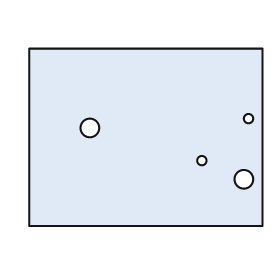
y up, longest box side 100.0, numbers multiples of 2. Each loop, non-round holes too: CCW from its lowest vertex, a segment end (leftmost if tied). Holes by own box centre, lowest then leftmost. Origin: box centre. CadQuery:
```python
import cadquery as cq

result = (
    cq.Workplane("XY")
    .moveTo(-50.0, -38.0)
    .lineTo(50.0, -38.0)
    .lineTo(50.0, 38.0)
    .lineTo(-50.0, 38.0)
    .close()
    .moveTo(42.0, -18.0)
    .circle(4.0)
    .moveTo(24.0, -10.0)
    .circle(2.0)
    .moveTo(-24.0, 4.0)
    .circle(4.0)
    .moveTo(44.0, 8.0)
    .circle(2.0)
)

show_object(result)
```